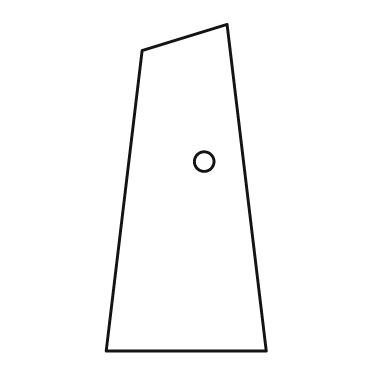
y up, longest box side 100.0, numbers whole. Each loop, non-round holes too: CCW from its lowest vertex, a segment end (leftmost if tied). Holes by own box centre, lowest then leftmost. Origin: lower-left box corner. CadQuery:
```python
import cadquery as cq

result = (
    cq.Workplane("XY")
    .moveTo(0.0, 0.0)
    .lineTo(49.0, 0.0)
    .lineTo(37.0, 100.0)
    .lineTo(11.0, 92.0)
    .close()
    .moveTo(30.0, 58.0)
    .circle(3.0)
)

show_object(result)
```